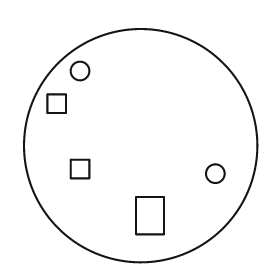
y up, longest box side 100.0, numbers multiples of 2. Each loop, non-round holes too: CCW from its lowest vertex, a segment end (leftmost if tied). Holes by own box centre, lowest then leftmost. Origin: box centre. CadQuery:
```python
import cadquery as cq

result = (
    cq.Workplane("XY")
    .moveTo(0.0, 0.0)
    .circle(50.0)
    .moveTo(-2.0, -38.0)
    .lineTo(10.0, -38.0)
    .lineTo(10.0, -22.0)
    .lineTo(-2.0, -22.0)
    .close()
    .moveTo(32.0, -12.0)
    .circle(4.0)
    .moveTo(-30.0, -14.0)
    .lineTo(-22.0, -14.0)
    .lineTo(-22.0, -6.0)
    .lineTo(-30.0, -6.0)
    .close()
    .moveTo(-40.0, 14.0)
    .lineTo(-32.0, 14.0)
    .lineTo(-32.0, 22.0)
    .lineTo(-40.0, 22.0)
    .close()
    .moveTo(-26.0, 32.0)
    .circle(4.0)
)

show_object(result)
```